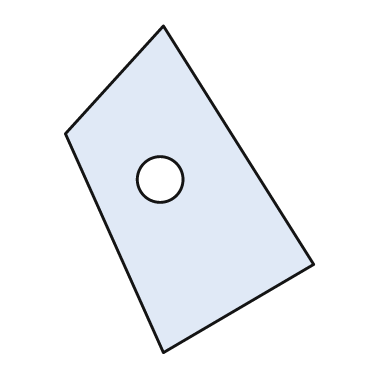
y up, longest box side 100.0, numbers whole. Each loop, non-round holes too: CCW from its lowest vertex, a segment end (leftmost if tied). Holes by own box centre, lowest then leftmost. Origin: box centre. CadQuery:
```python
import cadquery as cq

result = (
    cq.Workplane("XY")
    .moveTo(-8.0, -50.0)
    .lineTo(38.0, -23.0)
    .lineTo(-8.0, 50.0)
    .lineTo(-38.0, 17.0)
    .close()
    .moveTo(-9.0, 3.0)
    .circle(7.0)
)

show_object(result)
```